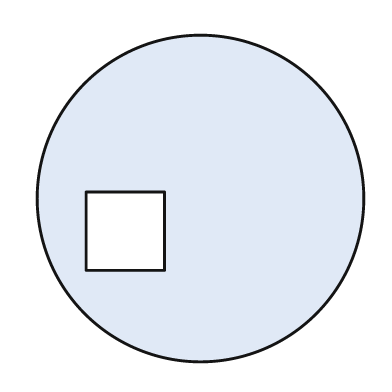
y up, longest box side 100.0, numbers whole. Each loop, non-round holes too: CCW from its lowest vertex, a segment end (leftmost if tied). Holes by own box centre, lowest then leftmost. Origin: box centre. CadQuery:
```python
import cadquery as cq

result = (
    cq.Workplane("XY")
    .moveTo(0.0, 0.0)
    .circle(50.0)
    .moveTo(-35.0, -22.0)
    .lineTo(-11.0, -22.0)
    .lineTo(-11.0, 2.0)
    .lineTo(-35.0, 2.0)
    .close()
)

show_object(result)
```